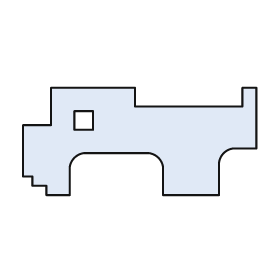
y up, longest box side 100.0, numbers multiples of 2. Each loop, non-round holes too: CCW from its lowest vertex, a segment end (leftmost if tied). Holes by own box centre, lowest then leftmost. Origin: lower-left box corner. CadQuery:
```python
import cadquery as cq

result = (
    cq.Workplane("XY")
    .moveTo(10.0, 0.0)
    .lineTo(20.0, 0.0)
    .lineTo(20.0, 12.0)
    .threePointArc((22.0, 16.0), (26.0, 18.0))
    .lineTo(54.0, 18.0)
    .threePointArc((58.0, 16.0), (60.0, 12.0))
    .lineTo(60.0, 0.0)
    .lineTo(84.0, 0.0)
    .lineTo(84.0, 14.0)
    .threePointArc((86.0, 18.0), (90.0, 20.0))
    .lineTo(100.0, 20.0)
    .lineTo(100.0, 46.0)
    .lineTo(94.0, 46.0)
    .lineTo(94.0, 38.0)
    .lineTo(48.0, 38.0)
    .lineTo(48.0, 46.0)
    .lineTo(12.0, 46.0)
    .lineTo(12.0, 30.0)
    .lineTo(0.0, 30.0)
    .lineTo(0.0, 8.0)
    .lineTo(4.0, 8.0)
    .lineTo(4.0, 4.0)
    .lineTo(10.0, 4.0)
    .close()
    .moveTo(22.0, 28.0)
    .lineTo(30.0, 28.0)
    .lineTo(30.0, 36.0)
    .lineTo(22.0, 36.0)
    .close()
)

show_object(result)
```